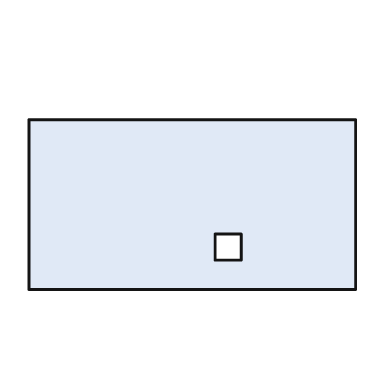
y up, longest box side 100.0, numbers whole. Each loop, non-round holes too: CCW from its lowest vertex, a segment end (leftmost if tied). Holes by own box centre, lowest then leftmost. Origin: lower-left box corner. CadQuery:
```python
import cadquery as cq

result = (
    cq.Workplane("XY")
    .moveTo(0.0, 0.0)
    .lineTo(100.0, 0.0)
    .lineTo(100.0, 52.0)
    .lineTo(0.0, 52.0)
    .close()
    .moveTo(57.0, 9.0)
    .lineTo(65.0, 9.0)
    .lineTo(65.0, 17.0)
    .lineTo(57.0, 17.0)
    .close()
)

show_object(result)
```